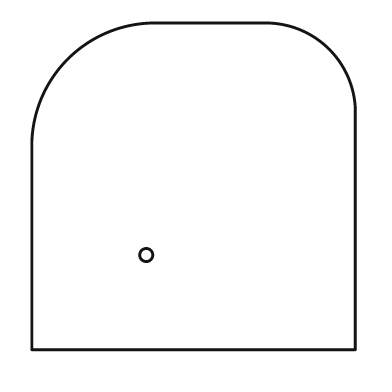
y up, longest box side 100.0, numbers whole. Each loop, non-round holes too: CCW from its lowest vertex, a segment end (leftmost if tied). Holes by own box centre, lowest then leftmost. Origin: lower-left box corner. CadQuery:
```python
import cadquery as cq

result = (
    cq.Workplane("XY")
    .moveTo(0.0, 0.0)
    .lineTo(99.0, 0.0)
    .lineTo(99.0, 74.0)
    .threePointArc((91.0, 92.0), (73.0, 100.0))
    .lineTo(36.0, 100.0)
    .threePointArc((11.0, 89.0), (0.0, 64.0))
    .close()
    .moveTo(35.0, 29.0)
    .circle(2.0)
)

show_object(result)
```